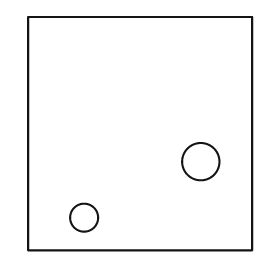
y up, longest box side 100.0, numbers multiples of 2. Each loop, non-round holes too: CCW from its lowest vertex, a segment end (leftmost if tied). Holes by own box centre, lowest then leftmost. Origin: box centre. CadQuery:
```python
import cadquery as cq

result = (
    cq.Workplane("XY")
    .moveTo(-48.0, -50.0)
    .lineTo(48.0, -50.0)
    .lineTo(48.0, 50.0)
    .lineTo(-48.0, 50.0)
    .close()
    .moveTo(-24.0, -36.0)
    .circle(6.0)
    .moveTo(26.0, -12.0)
    .circle(8.0)
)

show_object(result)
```